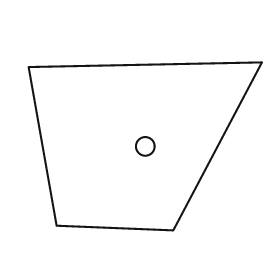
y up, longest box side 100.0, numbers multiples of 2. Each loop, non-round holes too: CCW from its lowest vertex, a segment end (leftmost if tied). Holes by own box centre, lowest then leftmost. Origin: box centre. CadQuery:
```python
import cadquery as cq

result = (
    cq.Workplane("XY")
    .moveTo(12.0, -36.0)
    .lineTo(50.0, 36.0)
    .lineTo(-50.0, 34.0)
    .lineTo(-38.0, -34.0)
    .close()
    .moveTo(0.0, 0.0)
    .circle(4.0)
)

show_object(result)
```